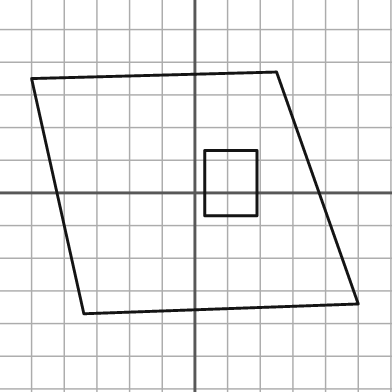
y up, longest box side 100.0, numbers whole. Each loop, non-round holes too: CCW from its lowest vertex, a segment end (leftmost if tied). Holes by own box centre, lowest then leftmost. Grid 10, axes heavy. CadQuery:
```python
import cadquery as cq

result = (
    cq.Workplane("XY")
    .moveTo(-34.0, -37.0)
    .lineTo(50.0, -34.0)
    .lineTo(25.0, 37.0)
    .lineTo(-50.0, 35.0)
    .close()
    .moveTo(3.0, -7.0)
    .lineTo(19.0, -7.0)
    .lineTo(19.0, 13.0)
    .lineTo(3.0, 13.0)
    .close()
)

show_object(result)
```